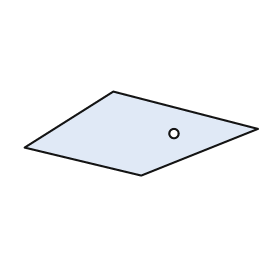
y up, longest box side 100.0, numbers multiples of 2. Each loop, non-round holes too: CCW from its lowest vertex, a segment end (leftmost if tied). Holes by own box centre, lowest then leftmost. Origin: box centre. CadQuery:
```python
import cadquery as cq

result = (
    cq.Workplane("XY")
    .moveTo(0.0, -18.0)
    .lineTo(50.0, 2.0)
    .lineTo(-12.0, 18.0)
    .lineTo(-50.0, -6.0)
    .close()
    .moveTo(14.0, 0.0)
    .circle(2.0)
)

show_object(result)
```